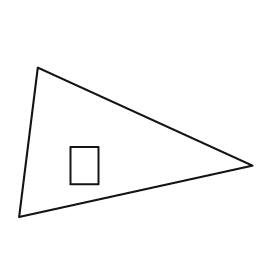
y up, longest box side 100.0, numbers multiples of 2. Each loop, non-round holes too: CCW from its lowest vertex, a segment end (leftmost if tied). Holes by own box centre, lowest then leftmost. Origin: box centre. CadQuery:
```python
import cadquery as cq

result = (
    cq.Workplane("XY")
    .moveTo(-50.0, -32.0)
    .lineTo(50.0, -10.0)
    .lineTo(-42.0, 32.0)
    .close()
    .moveTo(-28.0, -18.0)
    .lineTo(-16.0, -18.0)
    .lineTo(-16.0, -2.0)
    .lineTo(-28.0, -2.0)
    .close()
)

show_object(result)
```